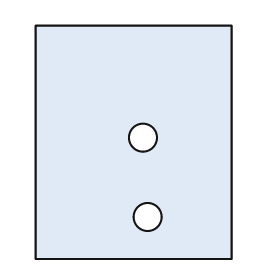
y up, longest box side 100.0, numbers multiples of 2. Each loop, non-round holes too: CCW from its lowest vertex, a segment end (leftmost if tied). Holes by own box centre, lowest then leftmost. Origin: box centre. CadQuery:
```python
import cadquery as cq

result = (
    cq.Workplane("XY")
    .moveTo(-42.0, -50.0)
    .lineTo(42.0, -50.0)
    .lineTo(42.0, 50.0)
    .lineTo(-42.0, 50.0)
    .close()
    .moveTo(6.0, -32.0)
    .circle(6.0)
    .moveTo(4.0, 2.0)
    .circle(6.0)
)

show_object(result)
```